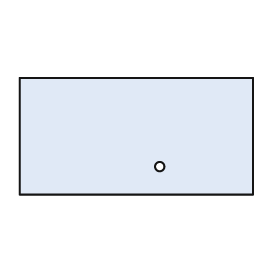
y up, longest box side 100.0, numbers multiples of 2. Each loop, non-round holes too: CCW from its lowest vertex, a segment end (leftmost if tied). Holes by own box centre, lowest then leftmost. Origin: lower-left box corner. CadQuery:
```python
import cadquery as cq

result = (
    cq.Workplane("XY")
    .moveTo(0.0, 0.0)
    .lineTo(100.0, 0.0)
    .lineTo(100.0, 50.0)
    .lineTo(0.0, 50.0)
    .close()
    .moveTo(60.0, 12.0)
    .circle(2.0)
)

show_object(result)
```